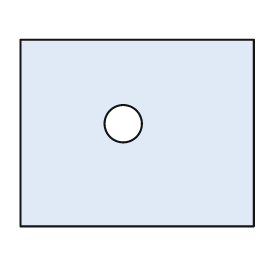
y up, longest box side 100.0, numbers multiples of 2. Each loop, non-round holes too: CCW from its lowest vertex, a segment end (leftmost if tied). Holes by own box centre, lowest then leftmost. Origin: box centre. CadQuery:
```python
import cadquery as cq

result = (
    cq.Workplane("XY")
    .moveTo(-50.0, -40.0)
    .lineTo(50.0, -40.0)
    .lineTo(50.0, 40.0)
    .lineTo(-50.0, 40.0)
    .close()
    .moveTo(-6.0, 4.0)
    .circle(8.0)
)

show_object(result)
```